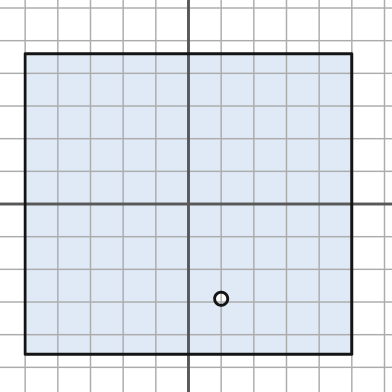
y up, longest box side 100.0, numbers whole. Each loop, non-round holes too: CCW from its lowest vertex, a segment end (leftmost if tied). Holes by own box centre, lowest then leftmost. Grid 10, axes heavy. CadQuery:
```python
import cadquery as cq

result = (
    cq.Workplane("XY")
    .moveTo(-50.0, -46.0)
    .lineTo(50.0, -46.0)
    .lineTo(50.0, 46.0)
    .lineTo(-50.0, 46.0)
    .close()
    .moveTo(10.0, -29.0)
    .circle(2.0)
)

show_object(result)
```